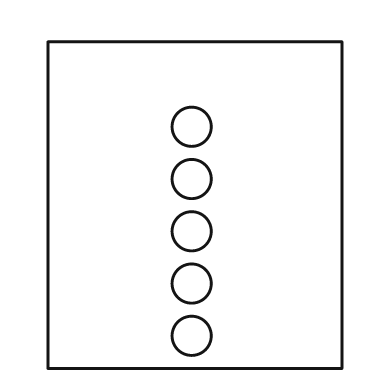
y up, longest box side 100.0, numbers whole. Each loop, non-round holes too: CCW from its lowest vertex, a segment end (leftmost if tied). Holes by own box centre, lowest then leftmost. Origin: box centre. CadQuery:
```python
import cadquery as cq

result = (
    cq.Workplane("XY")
    .moveTo(-45.0, -50.0)
    .lineTo(45.0, -50.0)
    .lineTo(45.0, 50.0)
    .lineTo(-45.0, 50.0)
    .close()
    .moveTo(-1.0, -40.0)
    .circle(6.0)
    .moveTo(-1.0, -24.0)
    .circle(6.0)
    .moveTo(-1.0, -8.0)
    .circle(6.0)
    .moveTo(-1.0, 8.0)
    .circle(6.0)
    .moveTo(-1.0, 24.0)
    .circle(6.0)
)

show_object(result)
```